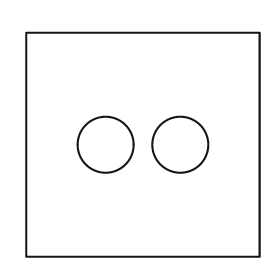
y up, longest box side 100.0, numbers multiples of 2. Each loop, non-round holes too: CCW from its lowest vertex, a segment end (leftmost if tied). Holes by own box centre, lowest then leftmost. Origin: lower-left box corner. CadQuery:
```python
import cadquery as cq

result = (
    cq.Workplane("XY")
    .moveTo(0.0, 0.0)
    .lineTo(100.0, 0.0)
    .lineTo(100.0, 96.0)
    .lineTo(0.0, 96.0)
    .close()
    .moveTo(34.0, 48.0)
    .circle(12.0)
    .moveTo(66.0, 48.0)
    .circle(12.0)
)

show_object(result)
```